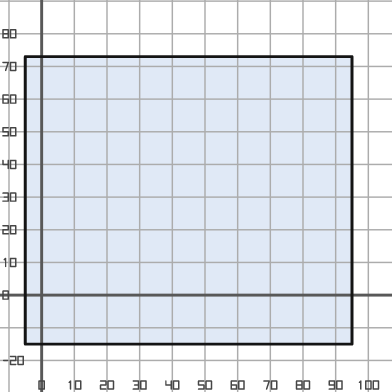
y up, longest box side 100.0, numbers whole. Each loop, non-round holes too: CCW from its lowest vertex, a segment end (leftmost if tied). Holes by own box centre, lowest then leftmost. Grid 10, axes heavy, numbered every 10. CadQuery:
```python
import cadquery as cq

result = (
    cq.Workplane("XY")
    .moveTo(-5.0, -15.0)
    .lineTo(95.0, -15.0)
    .lineTo(95.0, 73.0)
    .lineTo(-5.0, 73.0)
    .close()
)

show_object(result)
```